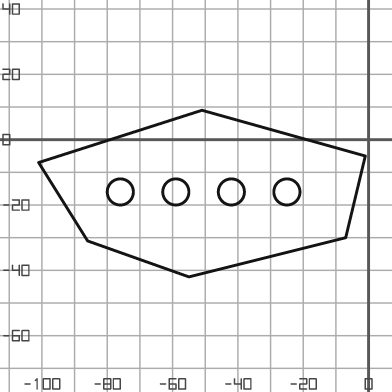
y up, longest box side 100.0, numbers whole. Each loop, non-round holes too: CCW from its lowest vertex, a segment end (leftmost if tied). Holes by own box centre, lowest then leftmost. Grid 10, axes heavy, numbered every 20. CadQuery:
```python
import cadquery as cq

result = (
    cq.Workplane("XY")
    .moveTo(-55.0, -42.0)
    .lineTo(-7.0, -30.0)
    .lineTo(-1.0, -5.0)
    .lineTo(-51.0, 9.0)
    .lineTo(-101.0, -7.0)
    .lineTo(-86.0, -31.0)
    .close()
    .moveTo(-76.0, -16.0)
    .circle(4.0)
    .moveTo(-59.0, -16.0)
    .circle(4.0)
    .moveTo(-42.0, -16.0)
    .circle(4.0)
    .moveTo(-25.0, -16.0)
    .circle(4.0)
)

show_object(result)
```